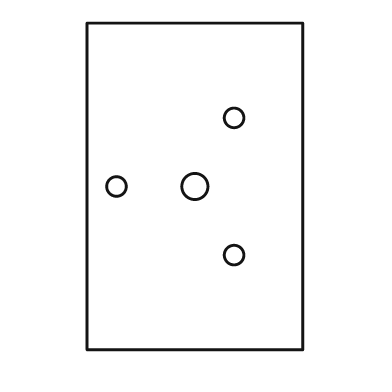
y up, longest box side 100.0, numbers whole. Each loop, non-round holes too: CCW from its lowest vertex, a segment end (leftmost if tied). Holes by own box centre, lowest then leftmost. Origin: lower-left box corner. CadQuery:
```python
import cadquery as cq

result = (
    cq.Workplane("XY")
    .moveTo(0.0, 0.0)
    .lineTo(66.0, 0.0)
    .lineTo(66.0, 100.0)
    .lineTo(0.0, 100.0)
    .close()
    .moveTo(45.0, 29.0)
    .circle(3.0)
    .moveTo(9.0, 50.0)
    .circle(3.0)
    .moveTo(33.0, 50.0)
    .circle(4.0)
    .moveTo(45.0, 71.0)
    .circle(3.0)
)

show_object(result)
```